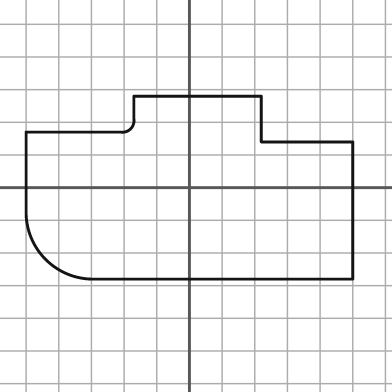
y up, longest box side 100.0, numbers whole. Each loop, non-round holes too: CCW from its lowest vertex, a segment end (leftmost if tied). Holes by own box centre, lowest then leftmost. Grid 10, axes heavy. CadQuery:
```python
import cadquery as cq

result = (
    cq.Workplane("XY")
    .moveTo(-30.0, -28.0)
    .lineTo(50.0, -28.0)
    .lineTo(50.0, 14.0)
    .lineTo(22.0, 14.0)
    .lineTo(22.0, 28.0)
    .lineTo(-17.0, 28.0)
    .lineTo(-17.0, 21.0)
    .threePointArc((-18.0, 18.0), (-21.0, 17.0))
    .lineTo(-50.0, 17.0)
    .lineTo(-50.0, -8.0)
    .threePointArc((-44.0, -22.0), (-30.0, -28.0))
    .close()
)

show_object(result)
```